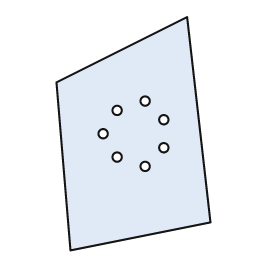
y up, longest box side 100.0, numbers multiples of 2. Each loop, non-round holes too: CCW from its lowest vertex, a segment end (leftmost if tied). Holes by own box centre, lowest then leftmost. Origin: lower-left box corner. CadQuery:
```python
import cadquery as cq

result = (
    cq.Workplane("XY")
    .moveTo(6.0, 0.0)
    .lineTo(66.0, 12.0)
    .lineTo(56.0, 100.0)
    .lineTo(0.0, 72.0)
    .close()
    .moveTo(38.0, 36.0)
    .circle(2.0)
    .moveTo(26.0, 40.0)
    .circle(2.0)
    .moveTo(46.0, 44.0)
    .circle(2.0)
    .moveTo(20.0, 50.0)
    .circle(2.0)
    .moveTo(46.0, 56.0)
    .circle(2.0)
    .moveTo(26.0, 60.0)
    .circle(2.0)
    .moveTo(38.0, 64.0)
    .circle(2.0)
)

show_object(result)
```